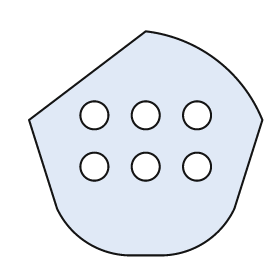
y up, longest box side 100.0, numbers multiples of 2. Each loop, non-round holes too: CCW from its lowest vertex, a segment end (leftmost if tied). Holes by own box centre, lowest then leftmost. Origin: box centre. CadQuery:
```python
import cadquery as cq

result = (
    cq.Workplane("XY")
    .moveTo(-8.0, -48.0)
    .lineTo(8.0, -48.0)
    .threePointArc((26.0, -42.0), (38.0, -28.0))
    .lineTo(50.0, 10.0)
    .threePointArc((30.0, 36.0), (0.0, 48.0))
    .lineTo(-50.0, 10.0)
    .lineTo(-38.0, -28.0)
    .threePointArc((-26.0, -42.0), (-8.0, -48.0))
    .close()
    .moveTo(-22.0, -10.0)
    .circle(6.0)
    .moveTo(0.0, -10.0)
    .circle(6.0)
    .moveTo(22.0, -10.0)
    .circle(6.0)
    .moveTo(-22.0, 12.0)
    .circle(6.0)
    .moveTo(0.0, 12.0)
    .circle(6.0)
    .moveTo(22.0, 12.0)
    .circle(6.0)
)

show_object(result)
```